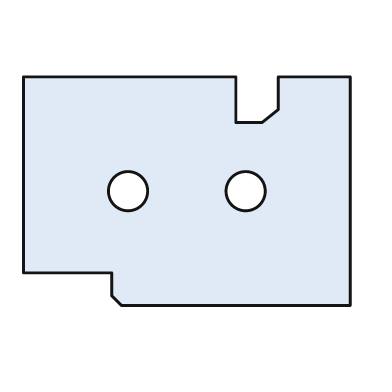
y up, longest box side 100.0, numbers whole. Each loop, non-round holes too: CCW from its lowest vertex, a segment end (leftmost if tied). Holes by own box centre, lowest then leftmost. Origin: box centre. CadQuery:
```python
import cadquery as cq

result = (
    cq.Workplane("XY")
    .moveTo(-20.0, -35.0)
    .lineTo(50.0, -35.0)
    .lineTo(50.0, 35.0)
    .lineTo(28.0, 35.0)
    .lineTo(28.0, 25.0)
    .lineTo(23.0, 21.0)
    .lineTo(15.0, 21.0)
    .lineTo(15.0, 35.0)
    .lineTo(-50.0, 35.0)
    .lineTo(-50.0, -25.0)
    .lineTo(-23.0, -25.0)
    .lineTo(-23.0, -32.0)
    .close()
    .moveTo(-18.0, 0.0)
    .circle(6.0)
    .moveTo(18.0, 0.0)
    .circle(6.0)
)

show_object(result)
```